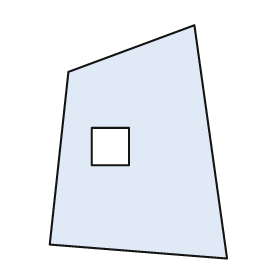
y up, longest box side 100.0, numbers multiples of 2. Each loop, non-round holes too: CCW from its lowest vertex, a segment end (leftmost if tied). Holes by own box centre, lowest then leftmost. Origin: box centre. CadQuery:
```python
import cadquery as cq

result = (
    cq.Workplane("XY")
    .moveTo(38.0, -50.0)
    .lineTo(24.0, 50.0)
    .lineTo(-30.0, 30.0)
    .lineTo(-38.0, -44.0)
    .close()
    .moveTo(-20.0, -10.0)
    .lineTo(-4.0, -10.0)
    .lineTo(-4.0, 6.0)
    .lineTo(-20.0, 6.0)
    .close()
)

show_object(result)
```